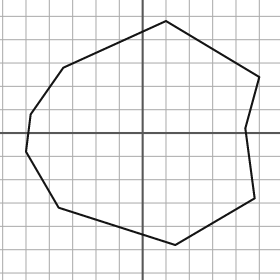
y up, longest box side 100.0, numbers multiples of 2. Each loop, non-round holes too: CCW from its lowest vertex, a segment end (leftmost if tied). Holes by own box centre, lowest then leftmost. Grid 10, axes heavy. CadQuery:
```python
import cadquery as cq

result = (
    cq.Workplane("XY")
    .moveTo(14.0, -48.0)
    .lineTo(48.0, -28.0)
    .lineTo(44.0, 2.0)
    .lineTo(50.0, 24.0)
    .lineTo(10.0, 48.0)
    .lineTo(-34.0, 28.0)
    .lineTo(-48.0, 8.0)
    .lineTo(-50.0, -8.0)
    .lineTo(-36.0, -32.0)
    .close()
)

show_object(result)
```